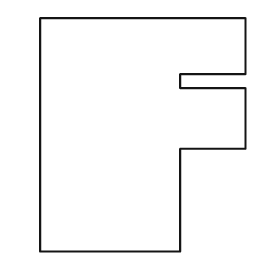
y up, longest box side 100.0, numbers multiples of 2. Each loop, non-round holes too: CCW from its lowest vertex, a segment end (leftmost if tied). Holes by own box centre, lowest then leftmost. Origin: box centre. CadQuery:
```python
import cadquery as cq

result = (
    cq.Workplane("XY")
    .moveTo(-44.0, -50.0)
    .lineTo(16.0, -50.0)
    .lineTo(16.0, -6.0)
    .lineTo(44.0, -6.0)
    .lineTo(44.0, 20.0)
    .lineTo(16.0, 20.0)
    .lineTo(16.0, 26.0)
    .lineTo(44.0, 26.0)
    .lineTo(44.0, 50.0)
    .lineTo(-44.0, 50.0)
    .close()
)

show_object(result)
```